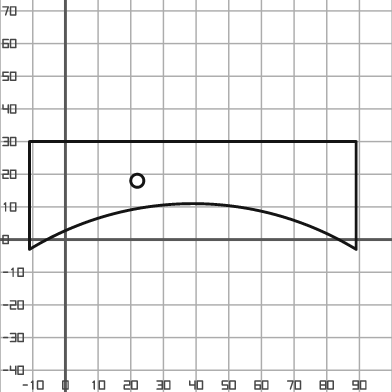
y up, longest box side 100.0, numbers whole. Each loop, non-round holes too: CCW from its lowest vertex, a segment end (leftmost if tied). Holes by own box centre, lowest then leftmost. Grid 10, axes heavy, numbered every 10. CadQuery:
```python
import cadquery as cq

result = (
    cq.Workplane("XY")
    .moveTo(-11.0, -3.0)
    .threePointArc((39.0, 11.0), (89.0, -3.0))
    .lineTo(89.0, 30.0)
    .lineTo(-11.0, 30.0)
    .close()
    .moveTo(22.0, 18.0)
    .circle(2.0)
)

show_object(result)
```